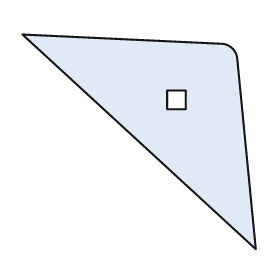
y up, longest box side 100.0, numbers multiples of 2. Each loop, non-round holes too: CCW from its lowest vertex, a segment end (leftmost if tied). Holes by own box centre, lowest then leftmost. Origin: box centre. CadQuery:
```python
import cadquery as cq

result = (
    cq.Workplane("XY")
    .moveTo(50.0, -46.0)
    .lineTo(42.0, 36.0)
    .threePointArc((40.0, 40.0), (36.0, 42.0))
    .lineTo(-50.0, 46.0)
    .close()
    .moveTo(12.0, 14.0)
    .lineTo(20.0, 14.0)
    .lineTo(20.0, 22.0)
    .lineTo(12.0, 22.0)
    .close()
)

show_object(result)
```